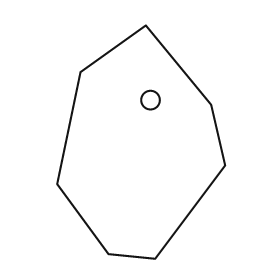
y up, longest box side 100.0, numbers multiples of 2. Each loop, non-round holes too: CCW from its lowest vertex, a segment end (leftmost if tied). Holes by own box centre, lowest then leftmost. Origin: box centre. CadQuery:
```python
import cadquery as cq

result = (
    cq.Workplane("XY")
    .moveTo(6.0, -50.0)
    .lineTo(36.0, -10.0)
    .lineTo(30.0, 16.0)
    .lineTo(2.0, 50.0)
    .lineTo(-26.0, 30.0)
    .lineTo(-36.0, -18.0)
    .lineTo(-14.0, -48.0)
    .close()
    .moveTo(4.0, 18.0)
    .circle(4.0)
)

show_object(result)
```